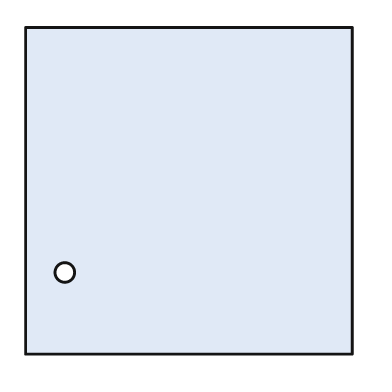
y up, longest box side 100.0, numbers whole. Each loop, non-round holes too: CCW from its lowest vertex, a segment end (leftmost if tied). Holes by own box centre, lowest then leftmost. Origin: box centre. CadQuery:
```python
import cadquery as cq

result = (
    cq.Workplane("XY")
    .moveTo(-50.0, -50.0)
    .lineTo(50.0, -50.0)
    .lineTo(50.0, 50.0)
    .lineTo(-50.0, 50.0)
    .close()
    .moveTo(-38.0, -25.0)
    .circle(3.0)
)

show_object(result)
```